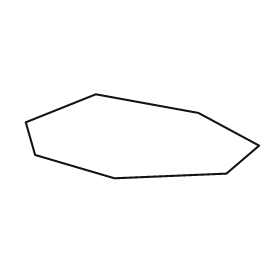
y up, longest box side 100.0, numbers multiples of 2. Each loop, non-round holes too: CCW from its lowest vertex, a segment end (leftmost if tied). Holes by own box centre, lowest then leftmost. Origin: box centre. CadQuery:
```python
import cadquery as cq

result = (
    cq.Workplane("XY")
    .moveTo(-12.0, -18.0)
    .lineTo(36.0, -16.0)
    .lineTo(50.0, -4.0)
    .lineTo(24.0, 10.0)
    .lineTo(-20.0, 18.0)
    .lineTo(-50.0, 6.0)
    .lineTo(-46.0, -8.0)
    .close()
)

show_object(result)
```